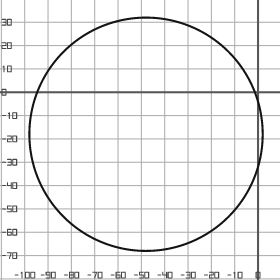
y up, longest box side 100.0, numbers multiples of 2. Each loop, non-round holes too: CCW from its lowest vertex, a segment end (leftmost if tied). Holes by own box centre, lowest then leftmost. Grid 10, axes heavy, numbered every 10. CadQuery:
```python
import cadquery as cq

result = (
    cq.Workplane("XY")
    .moveTo(-48.0, -18.0)
    .circle(50.0)
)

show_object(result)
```